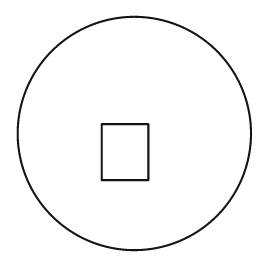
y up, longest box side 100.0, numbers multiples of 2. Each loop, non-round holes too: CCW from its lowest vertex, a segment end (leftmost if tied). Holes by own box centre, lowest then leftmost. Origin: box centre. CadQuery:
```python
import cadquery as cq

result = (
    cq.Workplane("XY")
    .moveTo(0.0, 0.0)
    .circle(50.0)
    .moveTo(-14.0, -20.0)
    .lineTo(6.0, -20.0)
    .lineTo(6.0, 4.0)
    .lineTo(-14.0, 4.0)
    .close()
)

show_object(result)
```